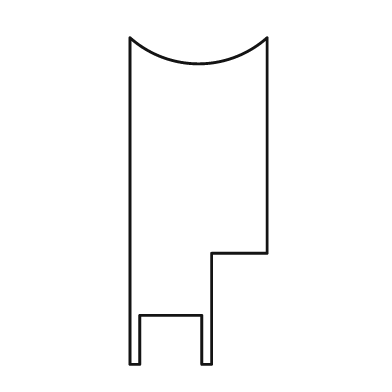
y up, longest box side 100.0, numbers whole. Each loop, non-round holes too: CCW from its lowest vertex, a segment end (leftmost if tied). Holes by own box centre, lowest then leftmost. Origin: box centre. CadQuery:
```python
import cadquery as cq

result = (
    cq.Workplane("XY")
    .moveTo(-21.0, -50.0)
    .lineTo(-18.0, -50.0)
    .lineTo(-18.0, -35.0)
    .lineTo(1.0, -35.0)
    .lineTo(1.0, -50.0)
    .lineTo(4.0, -50.0)
    .lineTo(4.0, -16.0)
    .lineTo(21.0, -16.0)
    .lineTo(21.0, 50.0)
    .threePointArc((0.0, 42.0), (-21.0, 50.0))
    .close()
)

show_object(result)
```